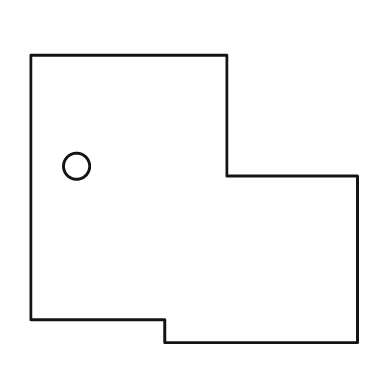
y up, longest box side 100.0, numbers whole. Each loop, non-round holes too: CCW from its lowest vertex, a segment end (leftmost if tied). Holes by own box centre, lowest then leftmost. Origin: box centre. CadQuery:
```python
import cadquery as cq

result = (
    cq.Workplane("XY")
    .moveTo(-9.0, -44.0)
    .lineTo(50.0, -44.0)
    .lineTo(50.0, 7.0)
    .lineTo(10.0, 7.0)
    .lineTo(10.0, 44.0)
    .lineTo(-50.0, 44.0)
    .lineTo(-50.0, -37.0)
    .lineTo(-9.0, -37.0)
    .close()
    .moveTo(-36.0, 10.0)
    .circle(4.0)
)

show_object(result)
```